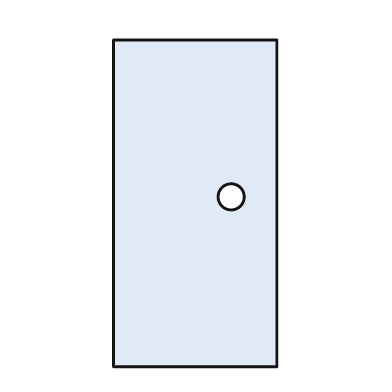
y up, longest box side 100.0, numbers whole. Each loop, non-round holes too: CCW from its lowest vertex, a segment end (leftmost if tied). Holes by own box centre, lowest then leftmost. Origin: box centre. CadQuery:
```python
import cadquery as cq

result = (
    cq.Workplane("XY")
    .moveTo(-25.0, -50.0)
    .lineTo(25.0, -50.0)
    .lineTo(25.0, 50.0)
    .lineTo(-25.0, 50.0)
    .close()
    .moveTo(11.0, 2.0)
    .circle(4.0)
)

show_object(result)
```